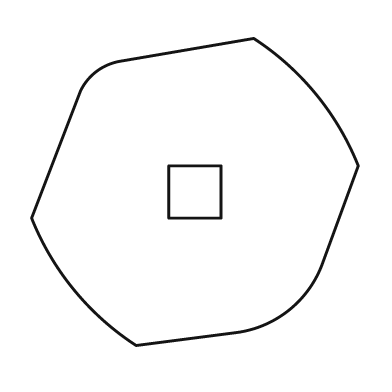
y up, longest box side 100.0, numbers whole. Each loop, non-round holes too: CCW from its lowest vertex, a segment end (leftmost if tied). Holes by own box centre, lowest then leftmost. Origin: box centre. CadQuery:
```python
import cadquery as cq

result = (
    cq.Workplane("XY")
    .moveTo(-18.0, -47.0)
    .lineTo(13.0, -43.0)
    .threePointArc((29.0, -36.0), (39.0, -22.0))
    .lineTo(50.0, 8.0)
    .threePointArc((37.0, 30.0), (18.0, 47.0))
    .lineTo(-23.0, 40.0)
    .threePointArc((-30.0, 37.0), (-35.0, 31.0))
    .lineTo(-50.0, -8.0)
    .threePointArc((-37.0, -30.0), (-18.0, -47.0))
    .close()
    .moveTo(-8.0, -8.0)
    .lineTo(8.0, -8.0)
    .lineTo(8.0, 8.0)
    .lineTo(-8.0, 8.0)
    .close()
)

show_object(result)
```